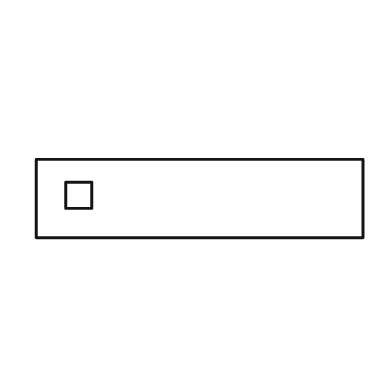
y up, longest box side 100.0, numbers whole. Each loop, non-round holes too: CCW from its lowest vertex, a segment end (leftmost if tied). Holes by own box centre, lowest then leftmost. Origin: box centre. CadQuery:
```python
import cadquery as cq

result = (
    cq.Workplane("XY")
    .moveTo(-50.0, -12.0)
    .lineTo(50.0, -12.0)
    .lineTo(50.0, 12.0)
    .lineTo(-50.0, 12.0)
    .close()
    .moveTo(-41.0, -3.0)
    .lineTo(-33.0, -3.0)
    .lineTo(-33.0, 5.0)
    .lineTo(-41.0, 5.0)
    .close()
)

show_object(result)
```